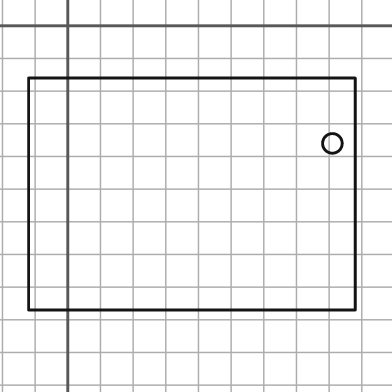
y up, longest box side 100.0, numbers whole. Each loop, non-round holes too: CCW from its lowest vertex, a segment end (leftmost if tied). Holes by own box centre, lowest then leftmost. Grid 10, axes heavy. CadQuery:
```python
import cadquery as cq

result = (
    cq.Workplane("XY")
    .moveTo(-12.0, -87.0)
    .lineTo(88.0, -87.0)
    .lineTo(88.0, -16.0)
    .lineTo(-12.0, -16.0)
    .close()
    .moveTo(81.0, -36.0)
    .circle(3.0)
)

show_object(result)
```